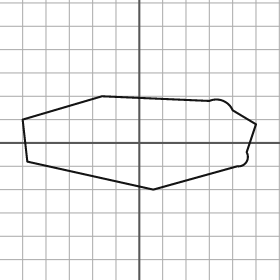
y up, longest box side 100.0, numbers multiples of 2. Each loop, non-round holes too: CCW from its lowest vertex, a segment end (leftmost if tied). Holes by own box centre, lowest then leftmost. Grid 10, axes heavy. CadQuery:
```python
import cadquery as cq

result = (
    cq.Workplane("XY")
    .moveTo(6.0, -20.0)
    .lineTo(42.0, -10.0)
    .threePointArc((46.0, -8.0), (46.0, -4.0))
    .lineTo(50.0, 8.0)
    .lineTo(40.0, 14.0)
    .threePointArc((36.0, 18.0), (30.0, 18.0))
    .lineTo(-16.0, 20.0)
    .lineTo(-50.0, 10.0)
    .lineTo(-48.0, -8.0)
    .close()
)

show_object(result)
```